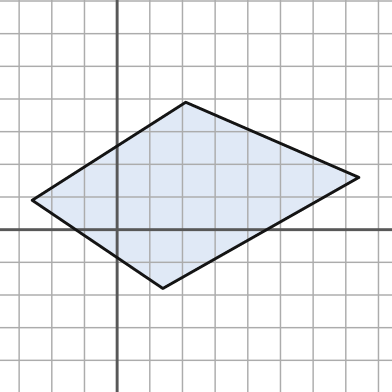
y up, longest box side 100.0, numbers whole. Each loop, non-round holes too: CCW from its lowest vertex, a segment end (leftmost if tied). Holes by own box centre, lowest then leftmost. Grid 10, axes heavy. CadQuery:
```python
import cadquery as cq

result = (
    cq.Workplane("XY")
    .moveTo(14.0, -18.0)
    .lineTo(74.0, 16.0)
    .lineTo(21.0, 39.0)
    .lineTo(-26.0, 9.0)
    .close()
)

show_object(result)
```